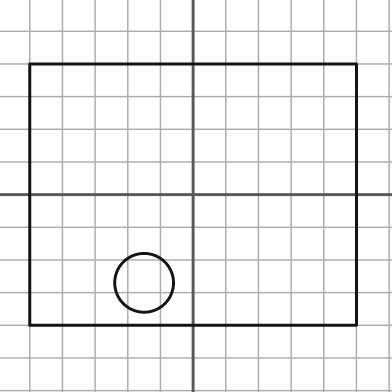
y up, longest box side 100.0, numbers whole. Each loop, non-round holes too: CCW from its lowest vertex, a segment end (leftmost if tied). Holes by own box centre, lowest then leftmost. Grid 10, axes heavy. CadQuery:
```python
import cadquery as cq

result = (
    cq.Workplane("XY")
    .moveTo(-50.0, -40.0)
    .lineTo(50.0, -40.0)
    .lineTo(50.0, 40.0)
    .lineTo(-50.0, 40.0)
    .close()
    .moveTo(-15.0, -27.0)
    .circle(9.0)
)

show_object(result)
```